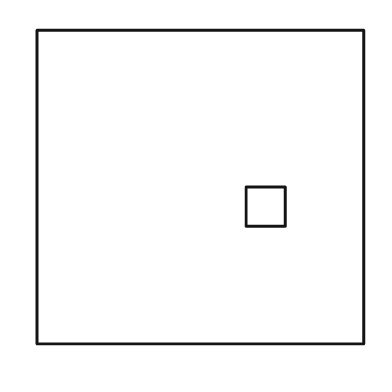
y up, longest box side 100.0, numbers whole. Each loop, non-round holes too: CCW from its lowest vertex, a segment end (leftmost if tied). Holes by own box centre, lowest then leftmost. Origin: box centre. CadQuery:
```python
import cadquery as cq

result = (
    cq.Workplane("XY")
    .moveTo(-50.0, -48.0)
    .lineTo(50.0, -48.0)
    .lineTo(50.0, 48.0)
    .lineTo(-50.0, 48.0)
    .close()
    .moveTo(14.0, -12.0)
    .lineTo(26.0, -12.0)
    .lineTo(26.0, 0.0)
    .lineTo(14.0, 0.0)
    .close()
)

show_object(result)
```